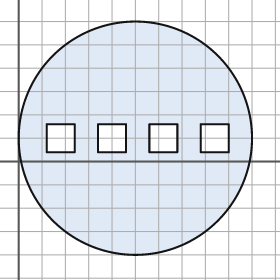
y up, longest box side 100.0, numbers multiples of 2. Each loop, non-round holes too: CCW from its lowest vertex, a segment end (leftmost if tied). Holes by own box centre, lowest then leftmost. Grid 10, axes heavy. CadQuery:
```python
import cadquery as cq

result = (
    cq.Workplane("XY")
    .moveTo(50.0, 10.0)
    .circle(50.0)
    .moveTo(12.0, 4.0)
    .lineTo(24.0, 4.0)
    .lineTo(24.0, 16.0)
    .lineTo(12.0, 16.0)
    .close()
    .moveTo(34.0, 4.0)
    .lineTo(46.0, 4.0)
    .lineTo(46.0, 16.0)
    .lineTo(34.0, 16.0)
    .close()
    .moveTo(56.0, 4.0)
    .lineTo(68.0, 4.0)
    .lineTo(68.0, 16.0)
    .lineTo(56.0, 16.0)
    .close()
    .moveTo(78.0, 4.0)
    .lineTo(90.0, 4.0)
    .lineTo(90.0, 16.0)
    .lineTo(78.0, 16.0)
    .close()
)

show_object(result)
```